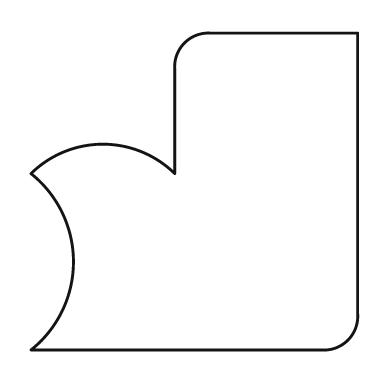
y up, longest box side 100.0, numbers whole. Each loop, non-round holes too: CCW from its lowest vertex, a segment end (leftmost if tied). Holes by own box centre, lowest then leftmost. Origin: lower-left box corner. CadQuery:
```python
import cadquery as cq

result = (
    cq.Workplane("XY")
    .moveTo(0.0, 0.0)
    .lineTo(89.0, 0.0)
    .threePointArc((97.0, 3.0), (100.0, 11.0))
    .lineTo(100.0, 97.0)
    .lineTo(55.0, 97.0)
    .threePointArc((47.0, 94.0), (44.0, 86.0))
    .lineTo(44.0, 54.0)
    .threePointArc((22.0, 63.0), (0.0, 54.0))
    .threePointArc((13.0, 27.0), (0.0, 0.0))
    .close()
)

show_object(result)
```